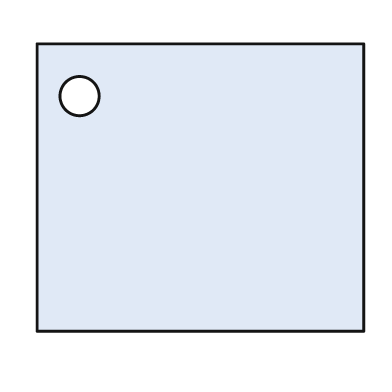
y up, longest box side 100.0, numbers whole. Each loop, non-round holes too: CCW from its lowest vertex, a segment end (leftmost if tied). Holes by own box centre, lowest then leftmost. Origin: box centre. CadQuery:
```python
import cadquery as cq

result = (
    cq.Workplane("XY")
    .moveTo(-50.0, -44.0)
    .lineTo(50.0, -44.0)
    .lineTo(50.0, 44.0)
    .lineTo(-50.0, 44.0)
    .close()
    .moveTo(-37.0, 28.0)
    .circle(6.0)
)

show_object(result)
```